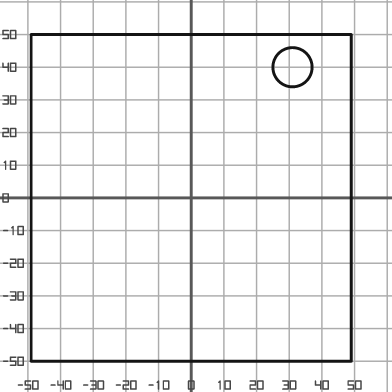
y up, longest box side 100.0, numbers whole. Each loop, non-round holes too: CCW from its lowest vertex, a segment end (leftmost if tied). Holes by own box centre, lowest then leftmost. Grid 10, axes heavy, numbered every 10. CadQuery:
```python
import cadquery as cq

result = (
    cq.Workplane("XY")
    .moveTo(-49.0, -50.0)
    .lineTo(49.0, -50.0)
    .lineTo(49.0, 50.0)
    .lineTo(-49.0, 50.0)
    .close()
    .moveTo(31.0, 40.0)
    .circle(6.0)
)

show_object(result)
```